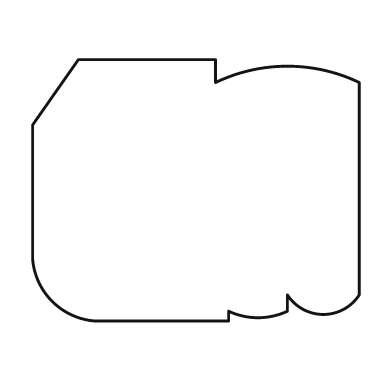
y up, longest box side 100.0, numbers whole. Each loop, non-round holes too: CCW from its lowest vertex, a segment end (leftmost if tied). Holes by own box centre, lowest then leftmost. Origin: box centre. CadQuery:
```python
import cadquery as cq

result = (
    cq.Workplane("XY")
    .moveTo(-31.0, -40.0)
    .lineTo(10.0, -40.0)
    .lineTo(10.0, -37.0)
    .threePointArc((19.0, -39.0), (28.0, -37.0))
    .lineTo(28.0, -32.0)
    .threePointArc((39.0, -38.0), (50.0, -32.0))
    .lineTo(50.0, 33.0)
    .threePointArc((28.0, 38.0), (6.0, 33.0))
    .lineTo(6.0, 40.0)
    .lineTo(-36.0, 40.0)
    .lineTo(-50.0, 20.0)
    .lineTo(-50.0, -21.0)
    .threePointArc((-44.0, -34.0), (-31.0, -40.0))
    .close()
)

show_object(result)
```